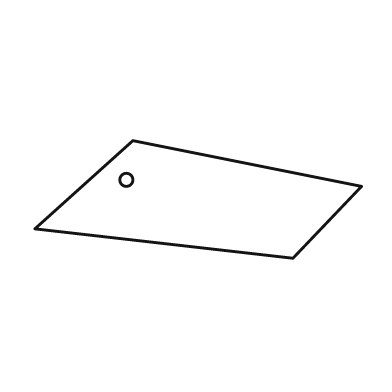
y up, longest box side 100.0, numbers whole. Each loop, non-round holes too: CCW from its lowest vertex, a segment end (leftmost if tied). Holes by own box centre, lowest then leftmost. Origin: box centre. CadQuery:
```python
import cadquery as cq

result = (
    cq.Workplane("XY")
    .moveTo(29.0, -18.0)
    .lineTo(50.0, 4.0)
    .lineTo(-20.0, 18.0)
    .lineTo(-50.0, -9.0)
    .close()
    .moveTo(-22.0, 6.0)
    .circle(2.0)
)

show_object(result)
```